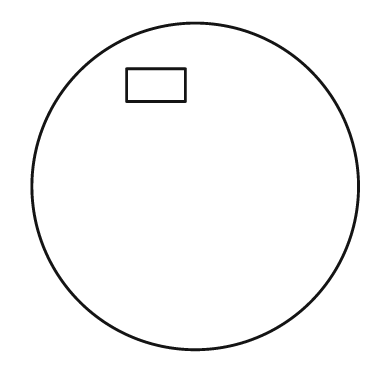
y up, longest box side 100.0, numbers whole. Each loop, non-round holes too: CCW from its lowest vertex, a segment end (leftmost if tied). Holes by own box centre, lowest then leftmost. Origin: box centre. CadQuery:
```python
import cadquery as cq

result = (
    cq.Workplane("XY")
    .moveTo(0.0, 0.0)
    .circle(50.0)
    .moveTo(-21.0, 26.0)
    .lineTo(-3.0, 26.0)
    .lineTo(-3.0, 36.0)
    .lineTo(-21.0, 36.0)
    .close()
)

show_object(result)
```